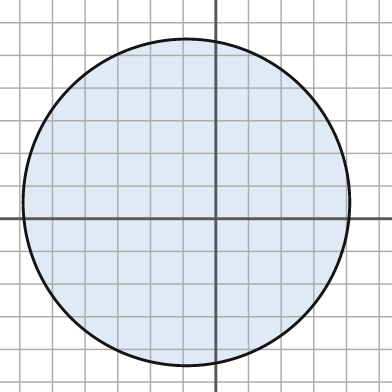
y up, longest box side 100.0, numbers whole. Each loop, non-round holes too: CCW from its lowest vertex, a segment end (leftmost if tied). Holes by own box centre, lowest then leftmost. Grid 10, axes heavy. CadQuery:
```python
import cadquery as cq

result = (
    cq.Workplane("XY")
    .moveTo(-9.0, 5.0)
    .circle(50.0)
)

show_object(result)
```